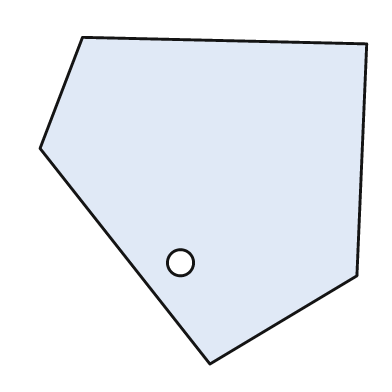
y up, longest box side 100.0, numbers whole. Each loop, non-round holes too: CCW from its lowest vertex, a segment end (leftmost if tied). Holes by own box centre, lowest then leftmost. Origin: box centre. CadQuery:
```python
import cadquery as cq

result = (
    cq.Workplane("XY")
    .moveTo(2.0, -50.0)
    .lineTo(47.0, -23.0)
    .lineTo(50.0, 48.0)
    .lineTo(-37.0, 50.0)
    .lineTo(-50.0, 16.0)
    .close()
    .moveTo(-7.0, -19.0)
    .circle(4.0)
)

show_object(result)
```